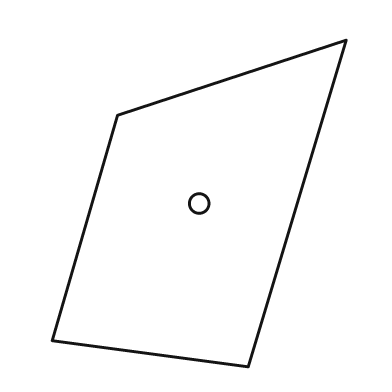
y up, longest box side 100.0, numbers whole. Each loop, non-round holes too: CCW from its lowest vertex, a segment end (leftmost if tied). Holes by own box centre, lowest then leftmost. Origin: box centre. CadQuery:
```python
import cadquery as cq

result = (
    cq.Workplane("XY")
    .moveTo(15.0, -50.0)
    .lineTo(45.0, 50.0)
    .lineTo(-25.0, 27.0)
    .lineTo(-45.0, -42.0)
    .close()
    .moveTo(0.0, 0.0)
    .circle(3.0)
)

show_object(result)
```